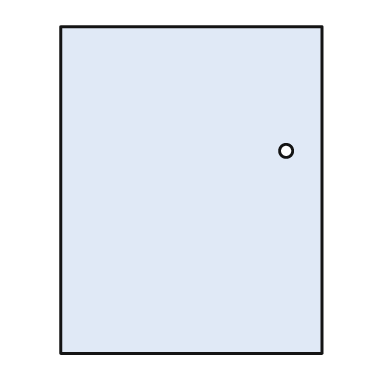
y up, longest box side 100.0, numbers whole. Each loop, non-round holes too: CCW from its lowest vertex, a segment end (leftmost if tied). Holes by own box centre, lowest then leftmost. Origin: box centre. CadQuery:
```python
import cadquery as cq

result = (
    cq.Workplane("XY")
    .moveTo(-40.0, -50.0)
    .lineTo(40.0, -50.0)
    .lineTo(40.0, 50.0)
    .lineTo(-40.0, 50.0)
    .close()
    .moveTo(29.0, 12.0)
    .circle(2.0)
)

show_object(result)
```